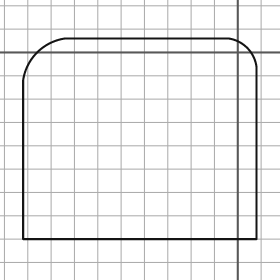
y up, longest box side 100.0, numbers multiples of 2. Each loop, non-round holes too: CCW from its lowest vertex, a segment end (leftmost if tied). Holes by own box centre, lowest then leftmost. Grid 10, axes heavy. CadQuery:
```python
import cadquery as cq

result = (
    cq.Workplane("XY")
    .moveTo(-92.0, -80.0)
    .lineTo(8.0, -80.0)
    .lineTo(8.0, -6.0)
    .threePointArc((4.0, 2.0), (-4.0, 6.0))
    .lineTo(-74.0, 6.0)
    .threePointArc((-86.0, 0.0), (-92.0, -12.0))
    .close()
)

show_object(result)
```